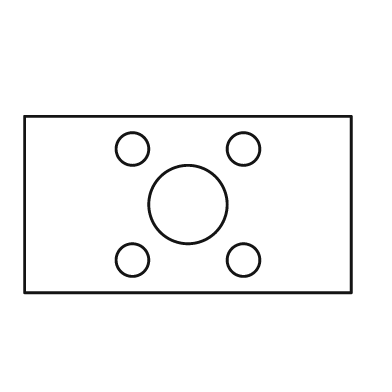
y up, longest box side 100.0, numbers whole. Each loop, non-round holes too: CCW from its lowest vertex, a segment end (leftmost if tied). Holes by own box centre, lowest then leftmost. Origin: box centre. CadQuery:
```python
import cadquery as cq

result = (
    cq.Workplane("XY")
    .moveTo(-50.0, -27.0)
    .lineTo(50.0, -27.0)
    .lineTo(50.0, 27.0)
    .lineTo(-50.0, 27.0)
    .close()
    .moveTo(-17.0, -17.0)
    .circle(5.0)
    .moveTo(17.0, -17.0)
    .circle(5.0)
    .moveTo(0.0, 0.0)
    .circle(12.0)
    .moveTo(-17.0, 17.0)
    .circle(5.0)
    .moveTo(17.0, 17.0)
    .circle(5.0)
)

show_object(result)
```